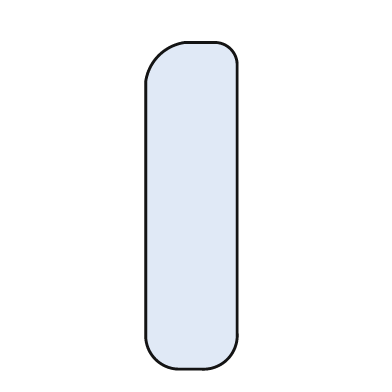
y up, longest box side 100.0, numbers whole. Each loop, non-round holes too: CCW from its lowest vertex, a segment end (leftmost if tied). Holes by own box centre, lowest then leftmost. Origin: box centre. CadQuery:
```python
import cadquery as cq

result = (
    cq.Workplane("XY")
    .moveTo(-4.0, -50.0)
    .lineTo(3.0, -50.0)
    .threePointArc((11.0, -47.0), (14.0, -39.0))
    .lineTo(14.0, 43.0)
    .threePointArc((12.0, 48.0), (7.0, 50.0))
    .lineTo(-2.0, 50.0)
    .threePointArc((-10.0, 46.0), (-14.0, 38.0))
    .lineTo(-14.0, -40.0)
    .threePointArc((-11.0, -47.0), (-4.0, -50.0))
    .close()
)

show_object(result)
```